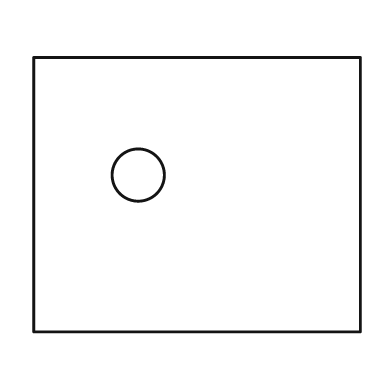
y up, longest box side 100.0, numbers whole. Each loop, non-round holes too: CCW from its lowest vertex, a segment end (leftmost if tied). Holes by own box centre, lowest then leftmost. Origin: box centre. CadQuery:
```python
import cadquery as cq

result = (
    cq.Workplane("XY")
    .moveTo(-50.0, -42.0)
    .lineTo(50.0, -42.0)
    .lineTo(50.0, 42.0)
    .lineTo(-50.0, 42.0)
    .close()
    .moveTo(-18.0, 6.0)
    .circle(8.0)
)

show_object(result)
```